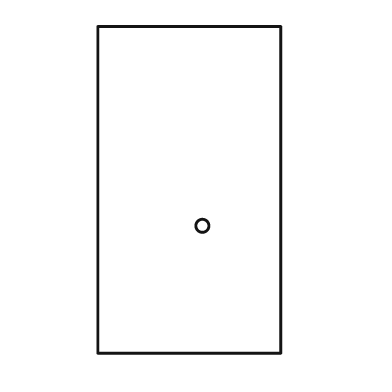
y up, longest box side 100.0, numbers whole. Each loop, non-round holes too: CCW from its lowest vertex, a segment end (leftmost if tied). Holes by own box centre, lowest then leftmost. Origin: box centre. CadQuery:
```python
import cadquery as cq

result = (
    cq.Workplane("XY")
    .moveTo(-28.0, -50.0)
    .lineTo(28.0, -50.0)
    .lineTo(28.0, 50.0)
    .lineTo(-28.0, 50.0)
    .close()
    .moveTo(4.0, -11.0)
    .circle(2.0)
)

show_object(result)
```